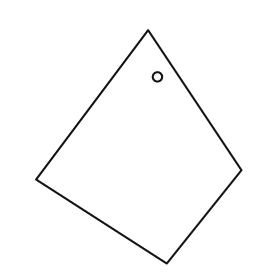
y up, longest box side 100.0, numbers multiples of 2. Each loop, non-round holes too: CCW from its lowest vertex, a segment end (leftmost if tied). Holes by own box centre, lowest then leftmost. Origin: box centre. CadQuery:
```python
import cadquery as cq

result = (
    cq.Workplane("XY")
    .moveTo(12.0, -50.0)
    .lineTo(44.0, -10.0)
    .lineTo(4.0, 50.0)
    .lineTo(-44.0, -14.0)
    .close()
    .moveTo(8.0, 30.0)
    .circle(2.0)
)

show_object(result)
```